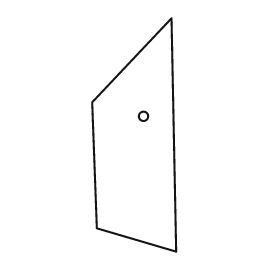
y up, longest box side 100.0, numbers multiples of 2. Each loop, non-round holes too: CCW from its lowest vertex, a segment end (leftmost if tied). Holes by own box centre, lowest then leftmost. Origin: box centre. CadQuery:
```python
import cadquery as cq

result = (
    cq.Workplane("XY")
    .moveTo(18.0, -50.0)
    .lineTo(16.0, 50.0)
    .lineTo(-18.0, 14.0)
    .lineTo(-16.0, -40.0)
    .close()
    .moveTo(4.0, 8.0)
    .circle(2.0)
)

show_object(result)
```